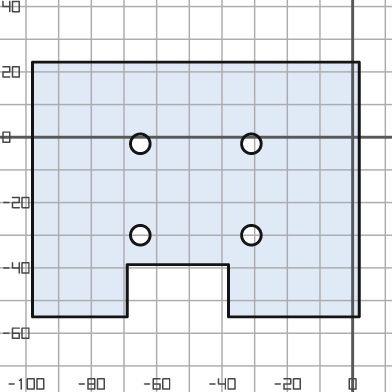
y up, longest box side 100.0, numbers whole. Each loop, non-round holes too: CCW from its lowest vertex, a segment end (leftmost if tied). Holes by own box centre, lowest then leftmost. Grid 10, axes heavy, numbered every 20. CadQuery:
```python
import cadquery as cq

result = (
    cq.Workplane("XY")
    .moveTo(-98.0, -55.0)
    .lineTo(-69.0, -55.0)
    .lineTo(-69.0, -39.0)
    .lineTo(-38.0, -39.0)
    .lineTo(-38.0, -55.0)
    .lineTo(2.0, -55.0)
    .lineTo(2.0, 23.0)
    .lineTo(-98.0, 23.0)
    .close()
    .moveTo(-65.0, -30.0)
    .circle(3.0)
    .moveTo(-31.0, -30.0)
    .circle(3.0)
    .moveTo(-65.0, -2.0)
    .circle(3.0)
    .moveTo(-31.0, -2.0)
    .circle(3.0)
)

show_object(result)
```